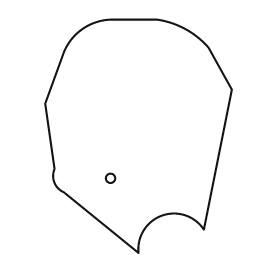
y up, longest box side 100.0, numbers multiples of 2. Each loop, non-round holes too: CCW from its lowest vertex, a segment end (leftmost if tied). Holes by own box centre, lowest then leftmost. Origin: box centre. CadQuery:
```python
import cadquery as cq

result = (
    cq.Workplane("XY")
    .moveTo(0.0, -50.0)
    .threePointArc((10.0, -34.0), (28.0, -40.0))
    .lineTo(40.0, 20.0)
    .lineTo(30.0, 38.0)
    .threePointArc((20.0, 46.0), (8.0, 50.0))
    .lineTo(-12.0, 50.0)
    .threePointArc((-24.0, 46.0), (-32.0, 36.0))
    .lineTo(-40.0, 14.0)
    .lineTo(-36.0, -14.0)
    .threePointArc((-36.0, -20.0), (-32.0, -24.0))
    .close()
    .moveTo(-12.0, -18.0)
    .circle(2.0)
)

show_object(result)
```